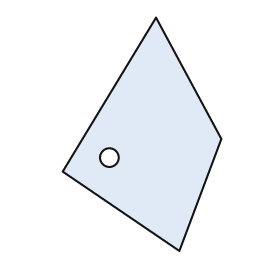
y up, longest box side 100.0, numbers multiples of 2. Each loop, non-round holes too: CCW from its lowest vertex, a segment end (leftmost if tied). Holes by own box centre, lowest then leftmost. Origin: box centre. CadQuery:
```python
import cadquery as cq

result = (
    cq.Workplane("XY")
    .moveTo(16.0, -50.0)
    .lineTo(34.0, -2.0)
    .lineTo(6.0, 50.0)
    .lineTo(-34.0, -16.0)
    .close()
    .moveTo(-14.0, -10.0)
    .circle(4.0)
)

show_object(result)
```